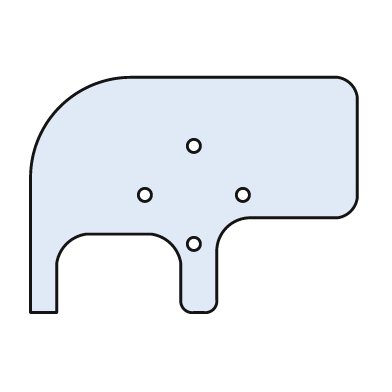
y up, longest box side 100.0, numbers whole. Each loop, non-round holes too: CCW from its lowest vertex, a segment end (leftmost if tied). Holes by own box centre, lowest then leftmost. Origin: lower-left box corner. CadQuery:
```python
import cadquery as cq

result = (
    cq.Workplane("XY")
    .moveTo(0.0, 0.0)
    .lineTo(8.0, 0.0)
    .lineTo(8.0, 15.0)
    .threePointArc((11.0, 21.0), (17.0, 24.0))
    .lineTo(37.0, 24.0)
    .threePointArc((43.0, 21.0), (46.0, 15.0))
    .lineTo(46.0, 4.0)
    .threePointArc((47.0, 1.0), (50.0, 0.0))
    .lineTo(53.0, 0.0)
    .threePointArc((56.0, 1.0), (57.0, 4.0))
    .lineTo(57.0, 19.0)
    .threePointArc((60.0, 26.0), (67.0, 29.0))
    .lineTo(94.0, 29.0)
    .threePointArc((98.0, 31.0), (100.0, 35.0))
    .lineTo(100.0, 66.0)
    .threePointArc((98.0, 70.0), (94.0, 72.0))
    .lineTo(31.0, 72.0)
    .threePointArc((9.0, 63.0), (0.0, 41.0))
    .close()
    .moveTo(50.0, 21.0)
    .circle(2.0)
    .moveTo(35.0, 36.0)
    .circle(2.0)
    .moveTo(65.0, 36.0)
    .circle(2.0)
    .moveTo(50.0, 51.0)
    .circle(2.0)
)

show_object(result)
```